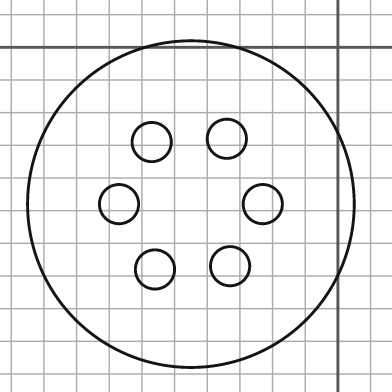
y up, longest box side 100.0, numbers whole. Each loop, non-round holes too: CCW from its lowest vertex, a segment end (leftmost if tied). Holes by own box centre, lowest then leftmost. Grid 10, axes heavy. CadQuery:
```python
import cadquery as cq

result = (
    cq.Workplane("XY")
    .moveTo(-45.0, -48.0)
    .circle(50.0)
    .moveTo(-56.0, -68.0)
    .circle(6.0)
    .moveTo(-33.0, -67.0)
    .circle(6.0)
    .moveTo(-67.0, -48.0)
    .circle(6.0)
    .moveTo(-23.0, -48.0)
    .circle(6.0)
    .moveTo(-57.0, -29.0)
    .circle(6.0)
    .moveTo(-34.0, -28.0)
    .circle(6.0)
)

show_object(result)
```